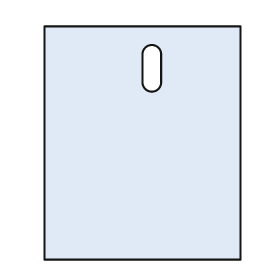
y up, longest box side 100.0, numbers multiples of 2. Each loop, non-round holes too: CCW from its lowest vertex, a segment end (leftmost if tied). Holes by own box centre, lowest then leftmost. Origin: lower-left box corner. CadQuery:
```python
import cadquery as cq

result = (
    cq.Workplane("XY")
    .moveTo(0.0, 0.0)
    .lineTo(84.0, 0.0)
    .lineTo(84.0, 100.0)
    .lineTo(0.0, 100.0)
    .close()
    .moveTo(42.0, 76.0)
    .threePointArc((46.0, 72.0), (50.0, 76.0))
    .lineTo(50.0, 88.0)
    .threePointArc((46.0, 92.0), (42.0, 88.0))
    .close()
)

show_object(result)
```